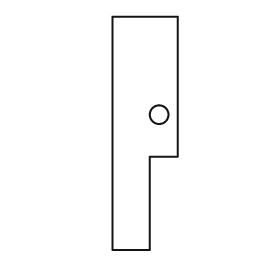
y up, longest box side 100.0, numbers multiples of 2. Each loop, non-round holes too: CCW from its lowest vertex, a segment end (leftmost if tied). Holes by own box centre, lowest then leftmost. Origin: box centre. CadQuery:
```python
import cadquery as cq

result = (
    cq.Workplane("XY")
    .moveTo(-14.0, -50.0)
    .lineTo(2.0, -50.0)
    .lineTo(2.0, -10.0)
    .lineTo(14.0, -10.0)
    .lineTo(14.0, 50.0)
    .lineTo(-14.0, 50.0)
    .close()
    .moveTo(6.0, 8.0)
    .circle(4.0)
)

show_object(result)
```